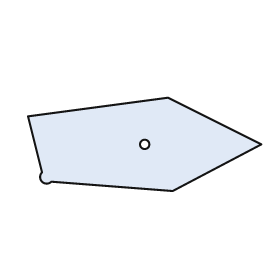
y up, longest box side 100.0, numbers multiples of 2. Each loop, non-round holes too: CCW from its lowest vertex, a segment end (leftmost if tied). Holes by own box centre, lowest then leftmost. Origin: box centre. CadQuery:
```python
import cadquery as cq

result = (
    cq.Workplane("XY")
    .moveTo(12.0, -20.0)
    .lineTo(50.0, 0.0)
    .lineTo(10.0, 20.0)
    .lineTo(-50.0, 12.0)
    .lineTo(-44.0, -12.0)
    .threePointArc((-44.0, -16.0), (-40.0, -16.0))
    .close()
    .moveTo(0.0, 0.0)
    .circle(2.0)
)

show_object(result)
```